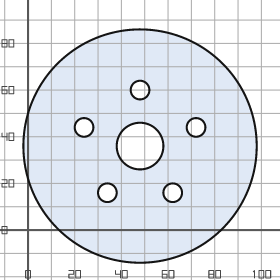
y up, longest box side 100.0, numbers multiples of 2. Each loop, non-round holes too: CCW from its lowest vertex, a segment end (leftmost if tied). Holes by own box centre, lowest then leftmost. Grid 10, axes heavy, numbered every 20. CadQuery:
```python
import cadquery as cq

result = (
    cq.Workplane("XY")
    .moveTo(48.0, 36.0)
    .circle(50.0)
    .moveTo(34.0, 16.0)
    .circle(4.0)
    .moveTo(62.0, 16.0)
    .circle(4.0)
    .moveTo(48.0, 36.0)
    .circle(10.0)
    .moveTo(24.0, 44.0)
    .circle(4.0)
    .moveTo(72.0, 44.0)
    .circle(4.0)
    .moveTo(48.0, 60.0)
    .circle(4.0)
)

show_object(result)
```